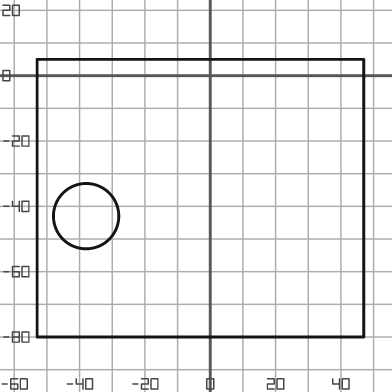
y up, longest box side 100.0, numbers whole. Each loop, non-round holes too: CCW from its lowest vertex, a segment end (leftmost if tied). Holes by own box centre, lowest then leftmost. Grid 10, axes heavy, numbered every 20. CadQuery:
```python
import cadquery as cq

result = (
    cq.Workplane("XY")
    .moveTo(-53.0, -80.0)
    .lineTo(47.0, -80.0)
    .lineTo(47.0, 5.0)
    .lineTo(-53.0, 5.0)
    .close()
    .moveTo(-38.0, -43.0)
    .circle(10.0)
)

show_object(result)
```